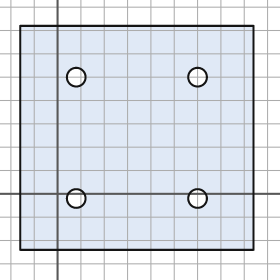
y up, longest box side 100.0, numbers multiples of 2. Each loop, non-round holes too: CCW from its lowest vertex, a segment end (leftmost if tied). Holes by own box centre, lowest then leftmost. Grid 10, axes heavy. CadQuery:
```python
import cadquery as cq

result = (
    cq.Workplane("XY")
    .moveTo(-16.0, -24.0)
    .lineTo(84.0, -24.0)
    .lineTo(84.0, 72.0)
    .lineTo(-16.0, 72.0)
    .close()
    .moveTo(8.0, -2.0)
    .circle(4.0)
    .moveTo(60.0, -2.0)
    .circle(4.0)
    .moveTo(8.0, 50.0)
    .circle(4.0)
    .moveTo(60.0, 50.0)
    .circle(4.0)
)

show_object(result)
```